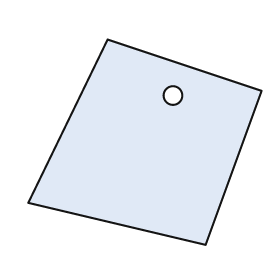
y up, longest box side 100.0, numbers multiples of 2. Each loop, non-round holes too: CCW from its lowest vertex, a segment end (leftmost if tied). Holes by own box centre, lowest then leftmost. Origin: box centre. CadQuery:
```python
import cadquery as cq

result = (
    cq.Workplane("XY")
    .moveTo(26.0, -44.0)
    .lineTo(50.0, 22.0)
    .lineTo(-16.0, 44.0)
    .lineTo(-50.0, -26.0)
    .close()
    .moveTo(12.0, 20.0)
    .circle(4.0)
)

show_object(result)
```